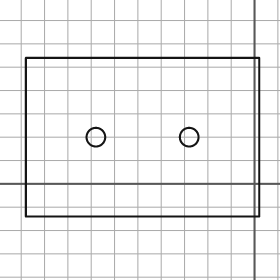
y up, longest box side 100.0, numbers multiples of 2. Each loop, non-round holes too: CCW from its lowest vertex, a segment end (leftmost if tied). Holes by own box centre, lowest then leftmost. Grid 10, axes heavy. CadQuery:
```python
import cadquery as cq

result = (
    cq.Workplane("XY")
    .moveTo(-98.0, -14.0)
    .lineTo(2.0, -14.0)
    .lineTo(2.0, 54.0)
    .lineTo(-98.0, 54.0)
    .close()
    .moveTo(-68.0, 20.0)
    .circle(4.0)
    .moveTo(-28.0, 20.0)
    .circle(4.0)
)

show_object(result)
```